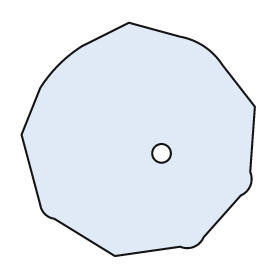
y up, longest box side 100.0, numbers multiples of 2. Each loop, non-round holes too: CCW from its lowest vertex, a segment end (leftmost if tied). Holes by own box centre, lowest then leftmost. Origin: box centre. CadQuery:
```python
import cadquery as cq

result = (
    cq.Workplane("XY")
    .moveTo(-10.0, -50.0)
    .lineTo(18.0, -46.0)
    .threePointArc((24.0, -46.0), (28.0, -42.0))
    .lineTo(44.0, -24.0)
    .threePointArc((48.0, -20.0), (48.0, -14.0))
    .lineTo(50.0, 14.0)
    .lineTo(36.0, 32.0)
    .threePointArc((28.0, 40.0), (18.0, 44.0))
    .lineTo(-4.0, 50.0)
    .lineTo(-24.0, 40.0)
    .threePointArc((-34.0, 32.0), (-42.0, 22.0))
    .lineTo(-50.0, 2.0)
    .lineTo(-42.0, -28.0)
    .threePointArc((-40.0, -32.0), (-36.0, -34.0))
    .close()
    .moveTo(10.0, -6.0)
    .circle(4.0)
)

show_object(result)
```